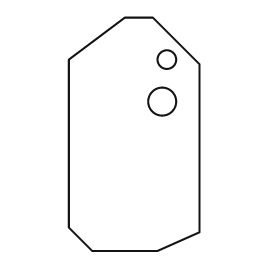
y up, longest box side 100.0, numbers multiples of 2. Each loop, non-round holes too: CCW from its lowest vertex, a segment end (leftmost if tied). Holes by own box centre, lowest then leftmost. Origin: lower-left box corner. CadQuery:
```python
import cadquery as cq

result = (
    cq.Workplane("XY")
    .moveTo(10.0, 0.0)
    .lineTo(38.0, 0.0)
    .lineTo(56.0, 8.0)
    .lineTo(56.0, 80.0)
    .lineTo(36.0, 100.0)
    .lineTo(24.0, 100.0)
    .lineTo(0.0, 82.0)
    .lineTo(0.0, 10.0)
    .close()
    .moveTo(40.0, 64.0)
    .circle(6.0)
    .moveTo(42.0, 82.0)
    .circle(4.0)
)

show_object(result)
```